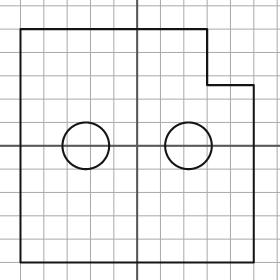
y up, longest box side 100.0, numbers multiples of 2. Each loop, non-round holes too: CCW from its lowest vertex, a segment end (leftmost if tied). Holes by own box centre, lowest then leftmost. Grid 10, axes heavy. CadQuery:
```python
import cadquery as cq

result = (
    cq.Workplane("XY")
    .moveTo(-50.0, -50.0)
    .lineTo(50.0, -50.0)
    .lineTo(50.0, 26.0)
    .lineTo(30.0, 26.0)
    .lineTo(30.0, 50.0)
    .lineTo(-50.0, 50.0)
    .close()
    .moveTo(-22.0, 0.0)
    .circle(10.0)
    .moveTo(22.0, 0.0)
    .circle(10.0)
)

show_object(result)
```